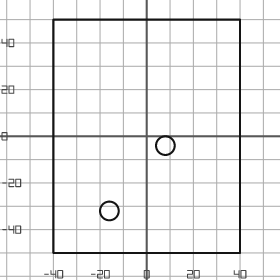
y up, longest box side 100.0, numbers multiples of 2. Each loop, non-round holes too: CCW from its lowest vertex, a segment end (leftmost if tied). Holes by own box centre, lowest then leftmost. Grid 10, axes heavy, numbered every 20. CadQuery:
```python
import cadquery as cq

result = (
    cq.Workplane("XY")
    .moveTo(-40.0, -50.0)
    .lineTo(40.0, -50.0)
    .lineTo(40.0, 50.0)
    .lineTo(-40.0, 50.0)
    .close()
    .moveTo(-16.0, -32.0)
    .circle(4.0)
    .moveTo(8.0, -4.0)
    .circle(4.0)
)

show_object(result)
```